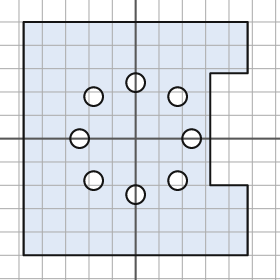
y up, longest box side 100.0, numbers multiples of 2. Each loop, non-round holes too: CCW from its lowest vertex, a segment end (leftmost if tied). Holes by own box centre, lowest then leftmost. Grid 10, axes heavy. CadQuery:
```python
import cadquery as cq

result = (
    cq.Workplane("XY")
    .moveTo(-48.0, -50.0)
    .lineTo(48.0, -50.0)
    .lineTo(48.0, -20.0)
    .lineTo(32.0, -20.0)
    .lineTo(32.0, 28.0)
    .lineTo(48.0, 28.0)
    .lineTo(48.0, 50.0)
    .lineTo(-48.0, 50.0)
    .close()
    .moveTo(0.0, -24.0)
    .circle(4.0)
    .moveTo(-18.0, -18.0)
    .circle(4.0)
    .moveTo(18.0, -18.0)
    .circle(4.0)
    .moveTo(-24.0, 0.0)
    .circle(4.0)
    .moveTo(24.0, 0.0)
    .circle(4.0)
    .moveTo(-18.0, 18.0)
    .circle(4.0)
    .moveTo(18.0, 18.0)
    .circle(4.0)
    .moveTo(0.0, 24.0)
    .circle(4.0)
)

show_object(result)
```